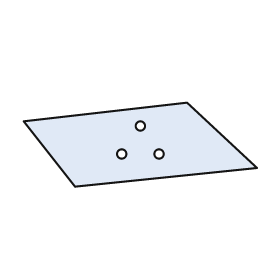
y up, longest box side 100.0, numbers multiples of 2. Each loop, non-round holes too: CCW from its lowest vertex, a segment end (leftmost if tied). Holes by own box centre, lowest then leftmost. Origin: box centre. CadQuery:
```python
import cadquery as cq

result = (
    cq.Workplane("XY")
    .moveTo(-28.0, -18.0)
    .lineTo(50.0, -10.0)
    .lineTo(20.0, 18.0)
    .lineTo(-50.0, 10.0)
    .close()
    .moveTo(-8.0, -4.0)
    .circle(2.0)
    .moveTo(8.0, -4.0)
    .circle(2.0)
    .moveTo(0.0, 8.0)
    .circle(2.0)
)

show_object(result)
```